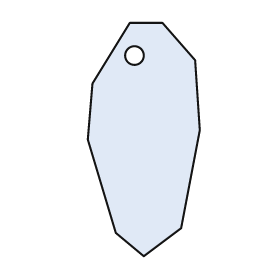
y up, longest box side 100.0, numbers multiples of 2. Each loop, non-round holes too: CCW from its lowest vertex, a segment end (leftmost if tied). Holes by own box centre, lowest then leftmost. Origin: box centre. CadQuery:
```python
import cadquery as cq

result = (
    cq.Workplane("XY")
    .moveTo(0.0, -50.0)
    .lineTo(16.0, -38.0)
    .lineTo(24.0, 4.0)
    .lineTo(22.0, 34.0)
    .lineTo(8.0, 50.0)
    .lineTo(-6.0, 50.0)
    .lineTo(-22.0, 24.0)
    .lineTo(-24.0, 0.0)
    .lineTo(-12.0, -40.0)
    .close()
    .moveTo(-4.0, 36.0)
    .circle(4.0)
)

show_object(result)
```